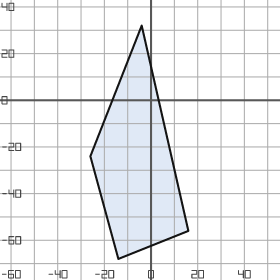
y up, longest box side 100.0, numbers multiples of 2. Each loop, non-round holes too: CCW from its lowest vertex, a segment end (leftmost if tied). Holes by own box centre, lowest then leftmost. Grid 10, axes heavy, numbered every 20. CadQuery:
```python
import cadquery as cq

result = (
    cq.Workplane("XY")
    .moveTo(-14.0, -68.0)
    .lineTo(16.0, -56.0)
    .lineTo(-4.0, 32.0)
    .lineTo(-26.0, -24.0)
    .close()
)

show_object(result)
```